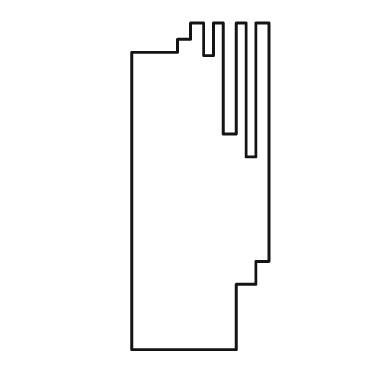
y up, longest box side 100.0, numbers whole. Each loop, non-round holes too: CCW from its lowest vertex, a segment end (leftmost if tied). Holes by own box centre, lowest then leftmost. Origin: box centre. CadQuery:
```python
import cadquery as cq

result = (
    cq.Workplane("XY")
    .moveTo(-21.0, -50.0)
    .lineTo(11.0, -50.0)
    .lineTo(11.0, -30.0)
    .lineTo(17.0, -30.0)
    .lineTo(17.0, -23.0)
    .lineTo(21.0, -23.0)
    .lineTo(21.0, 50.0)
    .lineTo(17.0, 50.0)
    .lineTo(17.0, 9.0)
    .lineTo(14.0, 9.0)
    .lineTo(14.0, 50.0)
    .lineTo(11.0, 50.0)
    .lineTo(11.0, 16.0)
    .lineTo(7.0, 16.0)
    .lineTo(7.0, 50.0)
    .lineTo(4.0, 50.0)
    .lineTo(4.0, 40.0)
    .lineTo(1.0, 40.0)
    .lineTo(1.0, 50.0)
    .lineTo(-3.0, 50.0)
    .lineTo(-3.0, 45.0)
    .lineTo(-7.0, 45.0)
    .lineTo(-7.0, 41.0)
    .lineTo(-21.0, 41.0)
    .close()
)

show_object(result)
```